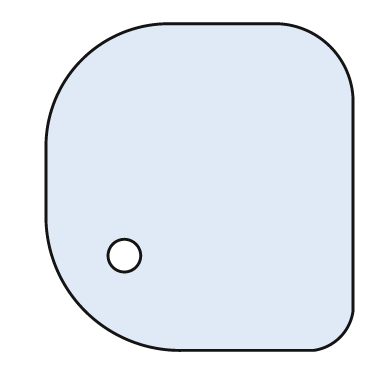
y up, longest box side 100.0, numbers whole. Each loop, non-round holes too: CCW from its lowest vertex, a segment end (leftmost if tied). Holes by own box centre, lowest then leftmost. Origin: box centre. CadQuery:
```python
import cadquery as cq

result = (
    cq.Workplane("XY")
    .moveTo(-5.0, -50.0)
    .lineTo(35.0, -50.0)
    .threePointArc((43.0, -46.0), (47.0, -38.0))
    .lineTo(47.0, 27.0)
    .threePointArc((40.0, 43.0), (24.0, 50.0))
    .lineTo(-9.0, 50.0)
    .threePointArc((-36.0, 39.0), (-47.0, 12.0))
    .lineTo(-47.0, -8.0)
    .threePointArc((-35.0, -38.0), (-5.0, -50.0))
    .close()
    .moveTo(-23.0, -21.0)
    .circle(5.0)
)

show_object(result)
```